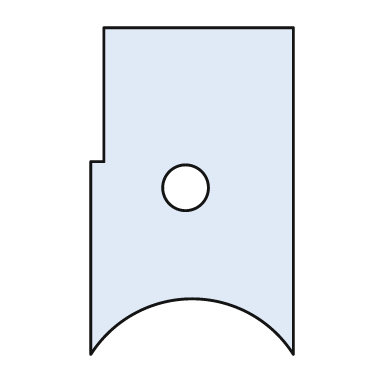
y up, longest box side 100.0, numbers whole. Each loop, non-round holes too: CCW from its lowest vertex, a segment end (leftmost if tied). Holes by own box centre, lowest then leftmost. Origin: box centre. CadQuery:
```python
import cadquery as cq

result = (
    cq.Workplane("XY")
    .moveTo(-31.0, -50.0)
    .threePointArc((0.0, -33.0), (31.0, -50.0))
    .lineTo(31.0, 50.0)
    .lineTo(-27.0, 50.0)
    .lineTo(-27.0, 9.0)
    .lineTo(-31.0, 9.0)
    .close()
    .moveTo(-2.0, 1.0)
    .circle(7.0)
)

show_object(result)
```